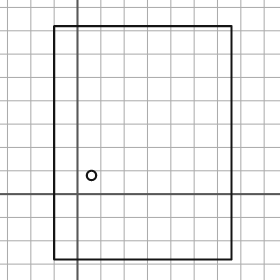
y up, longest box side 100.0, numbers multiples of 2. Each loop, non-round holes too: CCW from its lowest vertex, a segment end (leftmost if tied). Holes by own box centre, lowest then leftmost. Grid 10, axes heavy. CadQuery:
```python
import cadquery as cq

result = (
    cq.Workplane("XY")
    .moveTo(-10.0, -28.0)
    .lineTo(66.0, -28.0)
    .lineTo(66.0, 72.0)
    .lineTo(-10.0, 72.0)
    .close()
    .moveTo(6.0, 8.0)
    .circle(2.0)
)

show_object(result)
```